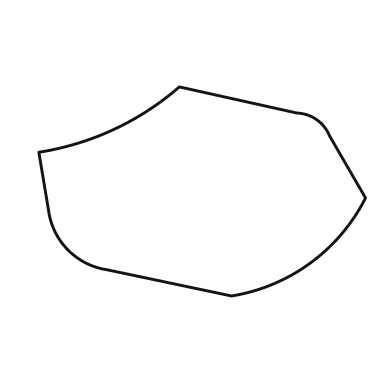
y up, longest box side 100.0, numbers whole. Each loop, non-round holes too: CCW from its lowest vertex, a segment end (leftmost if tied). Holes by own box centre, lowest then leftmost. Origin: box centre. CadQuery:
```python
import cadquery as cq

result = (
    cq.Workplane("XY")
    .moveTo(9.0, -32.0)
    .threePointArc((33.0, -22.0), (50.0, -2.0))
    .lineTo(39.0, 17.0)
    .threePointArc((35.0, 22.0), (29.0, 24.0))
    .lineTo(-7.0, 32.0)
    .threePointArc((-27.0, 19.0), (-50.0, 12.0))
    .lineTo(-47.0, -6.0)
    .threePointArc((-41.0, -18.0), (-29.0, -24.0))
    .close()
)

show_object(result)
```